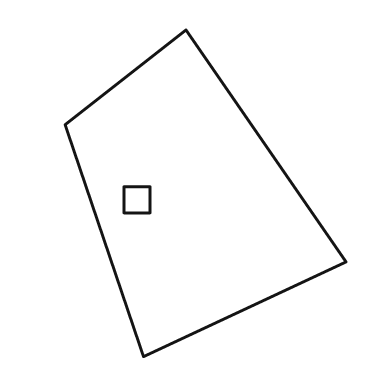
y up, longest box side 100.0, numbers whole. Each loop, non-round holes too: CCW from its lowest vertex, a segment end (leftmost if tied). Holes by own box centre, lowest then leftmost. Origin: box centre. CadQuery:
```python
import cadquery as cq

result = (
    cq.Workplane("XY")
    .moveTo(-19.0, -50.0)
    .lineTo(43.0, -21.0)
    .lineTo(-6.0, 50.0)
    .lineTo(-43.0, 21.0)
    .close()
    .moveTo(-25.0, -6.0)
    .lineTo(-17.0, -6.0)
    .lineTo(-17.0, 2.0)
    .lineTo(-25.0, 2.0)
    .close()
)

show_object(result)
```